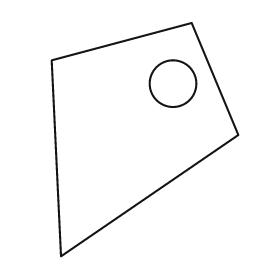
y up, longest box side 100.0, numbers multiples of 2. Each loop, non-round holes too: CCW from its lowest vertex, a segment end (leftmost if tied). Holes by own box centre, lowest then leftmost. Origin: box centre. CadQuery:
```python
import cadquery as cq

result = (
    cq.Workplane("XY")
    .moveTo(-36.0, -50.0)
    .lineTo(40.0, 2.0)
    .lineTo(20.0, 50.0)
    .lineTo(-40.0, 34.0)
    .close()
    .moveTo(12.0, 24.0)
    .circle(10.0)
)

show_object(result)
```